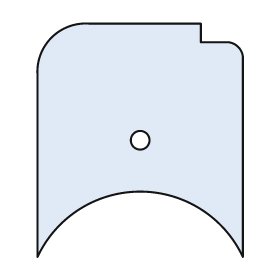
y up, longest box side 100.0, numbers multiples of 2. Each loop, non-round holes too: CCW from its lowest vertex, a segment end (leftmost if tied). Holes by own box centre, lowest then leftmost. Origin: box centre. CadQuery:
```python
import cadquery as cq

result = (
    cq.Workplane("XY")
    .moveTo(-44.0, -50.0)
    .threePointArc((0.0, -22.0), (44.0, -50.0))
    .lineTo(44.0, 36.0)
    .threePointArc((42.0, 40.0), (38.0, 42.0))
    .lineTo(26.0, 42.0)
    .lineTo(26.0, 50.0)
    .lineTo(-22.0, 50.0)
    .threePointArc((-38.0, 44.0), (-44.0, 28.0))
    .close()
    .moveTo(0.0, 0.0)
    .circle(4.0)
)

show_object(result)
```